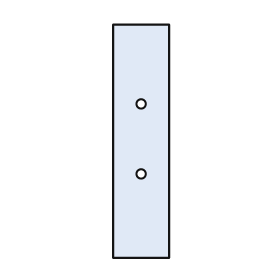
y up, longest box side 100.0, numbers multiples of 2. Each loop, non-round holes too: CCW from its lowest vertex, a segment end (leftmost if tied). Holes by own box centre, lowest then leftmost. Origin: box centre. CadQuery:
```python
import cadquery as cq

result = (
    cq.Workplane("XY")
    .moveTo(-12.0, -50.0)
    .lineTo(12.0, -50.0)
    .lineTo(12.0, 50.0)
    .lineTo(-12.0, 50.0)
    .close()
    .moveTo(0.0, -14.0)
    .circle(2.0)
    .moveTo(0.0, 16.0)
    .circle(2.0)
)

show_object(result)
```